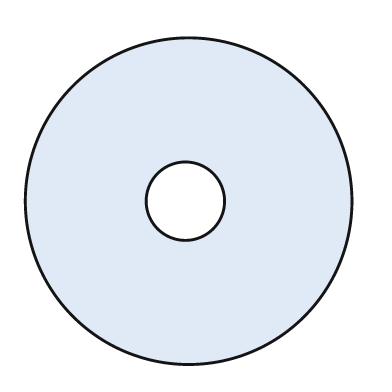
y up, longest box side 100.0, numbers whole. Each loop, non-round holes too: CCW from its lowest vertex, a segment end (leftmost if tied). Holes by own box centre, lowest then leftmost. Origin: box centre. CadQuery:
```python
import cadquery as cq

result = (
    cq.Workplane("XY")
    .moveTo(0.0, 0.0)
    .circle(50.0)
    .moveTo(-1.0, 0.0)
    .circle(12.0)
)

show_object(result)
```